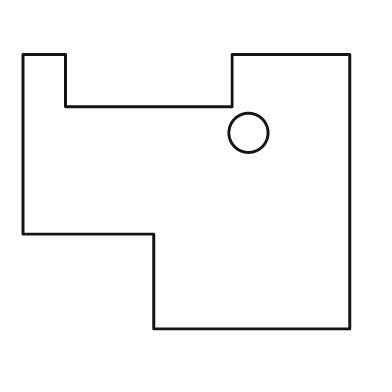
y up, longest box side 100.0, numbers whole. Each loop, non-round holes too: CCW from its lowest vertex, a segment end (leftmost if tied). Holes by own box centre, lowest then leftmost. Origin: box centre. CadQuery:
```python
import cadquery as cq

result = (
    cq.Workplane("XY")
    .moveTo(-10.0, -42.0)
    .lineTo(50.0, -42.0)
    .lineTo(50.0, 42.0)
    .lineTo(14.0, 42.0)
    .lineTo(14.0, 26.0)
    .lineTo(-37.0, 26.0)
    .lineTo(-37.0, 42.0)
    .lineTo(-50.0, 42.0)
    .lineTo(-50.0, -13.0)
    .lineTo(-10.0, -13.0)
    .close()
    .moveTo(19.0, 18.0)
    .circle(6.0)
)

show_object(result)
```